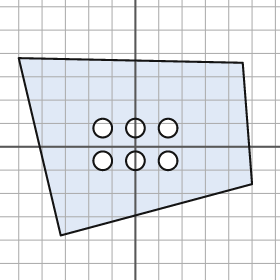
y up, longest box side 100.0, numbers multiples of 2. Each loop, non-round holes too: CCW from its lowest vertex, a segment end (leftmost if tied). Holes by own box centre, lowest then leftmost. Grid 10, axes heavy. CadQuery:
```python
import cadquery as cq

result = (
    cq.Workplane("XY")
    .moveTo(-32.0, -38.0)
    .lineTo(50.0, -16.0)
    .lineTo(46.0, 36.0)
    .lineTo(-50.0, 38.0)
    .close()
    .moveTo(-14.0, -6.0)
    .circle(4.0)
    .moveTo(0.0, -6.0)
    .circle(4.0)
    .moveTo(14.0, -6.0)
    .circle(4.0)
    .moveTo(-14.0, 8.0)
    .circle(4.0)
    .moveTo(0.0, 8.0)
    .circle(4.0)
    .moveTo(14.0, 8.0)
    .circle(4.0)
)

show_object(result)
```